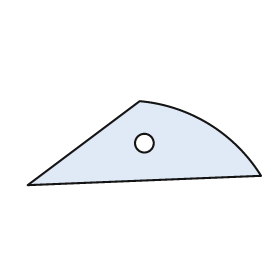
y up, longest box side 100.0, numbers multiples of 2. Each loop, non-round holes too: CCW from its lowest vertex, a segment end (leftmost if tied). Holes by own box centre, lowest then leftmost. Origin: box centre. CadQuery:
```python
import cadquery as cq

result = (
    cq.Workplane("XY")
    .moveTo(-50.0, -18.0)
    .lineTo(50.0, -14.0)
    .threePointArc((28.0, 8.0), (-2.0, 18.0))
    .close()
    .moveTo(0.0, 0.0)
    .circle(4.0)
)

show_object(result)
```